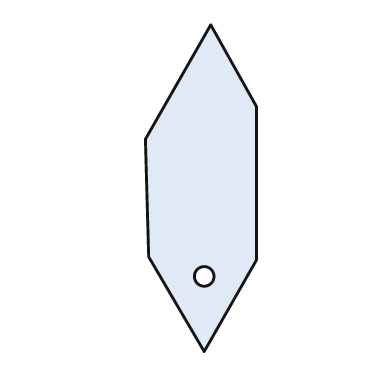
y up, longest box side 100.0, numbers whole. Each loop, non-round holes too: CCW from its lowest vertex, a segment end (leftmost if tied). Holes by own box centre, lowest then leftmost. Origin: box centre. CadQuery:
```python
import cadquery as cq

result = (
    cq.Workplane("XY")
    .moveTo(1.0, -50.0)
    .lineTo(17.0, -22.0)
    .lineTo(17.0, 25.0)
    .lineTo(3.0, 50.0)
    .lineTo(-17.0, 15.0)
    .lineTo(-16.0, -21.0)
    .close()
    .moveTo(1.0, -27.0)
    .circle(3.0)
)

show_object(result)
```